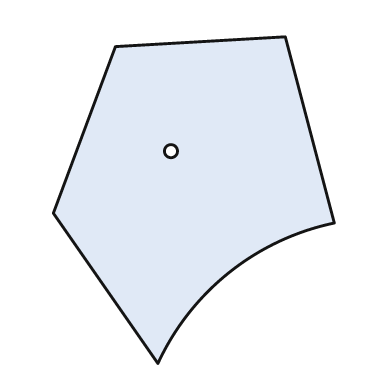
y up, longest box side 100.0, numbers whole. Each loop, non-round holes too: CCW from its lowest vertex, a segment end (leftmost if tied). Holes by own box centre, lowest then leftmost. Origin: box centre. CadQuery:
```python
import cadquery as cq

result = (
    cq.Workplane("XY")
    .moveTo(-11.0, -50.0)
    .threePointArc((11.0, -22.0), (43.0, -7.0))
    .lineTo(28.0, 50.0)
    .lineTo(-24.0, 47.0)
    .lineTo(-43.0, -4.0)
    .close()
    .moveTo(-7.0, 15.0)
    .circle(2.0)
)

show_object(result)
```